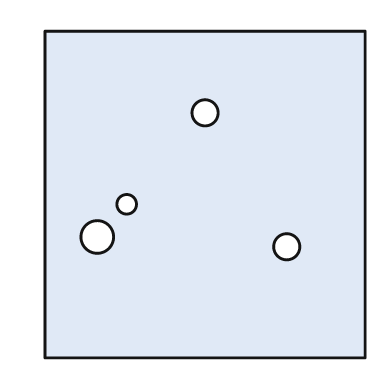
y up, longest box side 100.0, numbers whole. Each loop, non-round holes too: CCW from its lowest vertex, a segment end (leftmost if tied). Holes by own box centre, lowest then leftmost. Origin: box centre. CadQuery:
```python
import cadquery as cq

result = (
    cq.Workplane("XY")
    .moveTo(-49.0, -50.0)
    .lineTo(49.0, -50.0)
    .lineTo(49.0, 50.0)
    .lineTo(-49.0, 50.0)
    .close()
    .moveTo(25.0, -16.0)
    .circle(4.0)
    .moveTo(-33.0, -13.0)
    .circle(5.0)
    .moveTo(-24.0, -3.0)
    .circle(3.0)
    .moveTo(0.0, 25.0)
    .circle(4.0)
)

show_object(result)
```